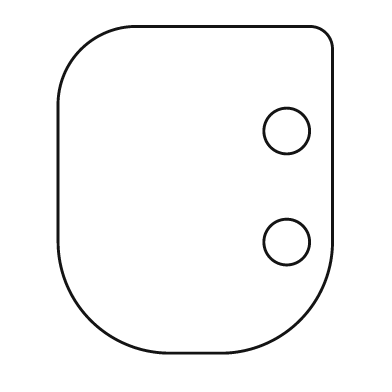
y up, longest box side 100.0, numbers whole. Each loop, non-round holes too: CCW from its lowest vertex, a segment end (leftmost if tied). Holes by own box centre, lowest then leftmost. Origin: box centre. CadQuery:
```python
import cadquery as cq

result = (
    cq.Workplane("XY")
    .moveTo(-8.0, -50.0)
    .lineTo(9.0, -50.0)
    .threePointArc((32.0, -40.0), (42.0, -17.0))
    .lineTo(42.0, 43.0)
    .threePointArc((40.0, 48.0), (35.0, 50.0))
    .lineTo(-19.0, 50.0)
    .threePointArc((-35.0, 43.0), (-42.0, 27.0))
    .lineTo(-42.0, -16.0)
    .threePointArc((-32.0, -40.0), (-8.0, -50.0))
    .close()
    .moveTo(28.0, -16.0)
    .circle(7.0)
    .moveTo(28.0, 18.0)
    .circle(7.0)
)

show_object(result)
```